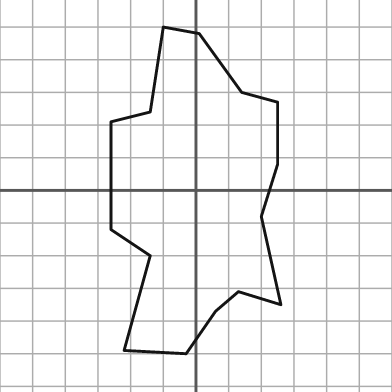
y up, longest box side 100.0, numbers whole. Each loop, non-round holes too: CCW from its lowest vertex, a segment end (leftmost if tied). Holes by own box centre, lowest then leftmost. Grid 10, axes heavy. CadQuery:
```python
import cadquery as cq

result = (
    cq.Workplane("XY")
    .moveTo(-3.0, -50.0)
    .lineTo(6.0, -37.0)
    .lineTo(13.0, -31.0)
    .lineTo(26.0, -35.0)
    .lineTo(20.0, -8.0)
    .lineTo(25.0, 8.0)
    .lineTo(25.0, 27.0)
    .lineTo(14.0, 30.0)
    .lineTo(1.0, 48.0)
    .lineTo(-10.0, 50.0)
    .lineTo(-14.0, 24.0)
    .lineTo(-26.0, 21.0)
    .lineTo(-26.0, -12.0)
    .lineTo(-14.0, -20.0)
    .lineTo(-22.0, -49.0)
    .close()
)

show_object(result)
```